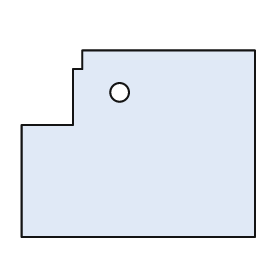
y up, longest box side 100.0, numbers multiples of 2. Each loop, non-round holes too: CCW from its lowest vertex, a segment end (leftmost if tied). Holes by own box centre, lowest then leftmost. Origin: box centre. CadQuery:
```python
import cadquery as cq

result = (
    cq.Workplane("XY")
    .moveTo(-50.0, -40.0)
    .lineTo(50.0, -40.0)
    .lineTo(50.0, 40.0)
    .lineTo(-24.0, 40.0)
    .lineTo(-24.0, 32.0)
    .lineTo(-28.0, 32.0)
    .lineTo(-28.0, 8.0)
    .lineTo(-50.0, 8.0)
    .close()
    .moveTo(-8.0, 22.0)
    .circle(4.0)
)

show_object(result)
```